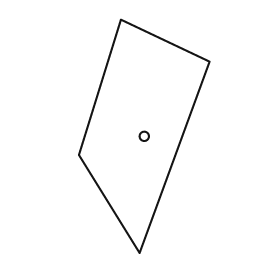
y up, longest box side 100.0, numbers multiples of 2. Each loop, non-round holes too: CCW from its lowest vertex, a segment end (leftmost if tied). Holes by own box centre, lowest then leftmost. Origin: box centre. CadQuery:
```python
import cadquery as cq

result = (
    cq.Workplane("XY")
    .moveTo(-2.0, -50.0)
    .lineTo(28.0, 32.0)
    .lineTo(-10.0, 50.0)
    .lineTo(-28.0, -8.0)
    .close()
    .moveTo(0.0, 0.0)
    .circle(2.0)
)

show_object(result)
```